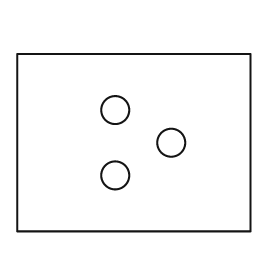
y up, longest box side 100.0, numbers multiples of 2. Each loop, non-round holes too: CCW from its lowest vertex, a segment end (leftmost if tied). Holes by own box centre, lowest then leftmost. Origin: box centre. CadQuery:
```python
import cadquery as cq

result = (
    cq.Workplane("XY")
    .moveTo(-50.0, -38.0)
    .lineTo(50.0, -38.0)
    .lineTo(50.0, 38.0)
    .lineTo(-50.0, 38.0)
    .close()
    .moveTo(-8.0, -14.0)
    .circle(6.0)
    .moveTo(16.0, 0.0)
    .circle(6.0)
    .moveTo(-8.0, 14.0)
    .circle(6.0)
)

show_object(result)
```